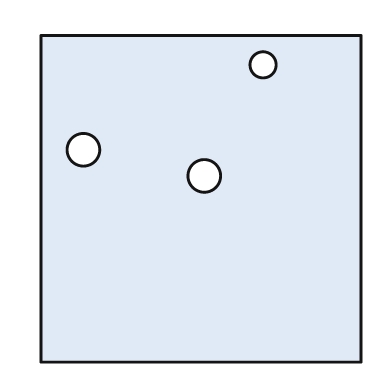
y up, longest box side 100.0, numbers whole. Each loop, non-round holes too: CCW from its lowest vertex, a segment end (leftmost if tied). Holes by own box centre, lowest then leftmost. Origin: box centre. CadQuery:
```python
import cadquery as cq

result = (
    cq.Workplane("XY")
    .moveTo(-49.0, -50.0)
    .lineTo(49.0, -50.0)
    .lineTo(49.0, 50.0)
    .lineTo(-49.0, 50.0)
    .close()
    .moveTo(1.0, 7.0)
    .circle(5.0)
    .moveTo(-36.0, 15.0)
    .circle(5.0)
    .moveTo(19.0, 41.0)
    .circle(4.0)
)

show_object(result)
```